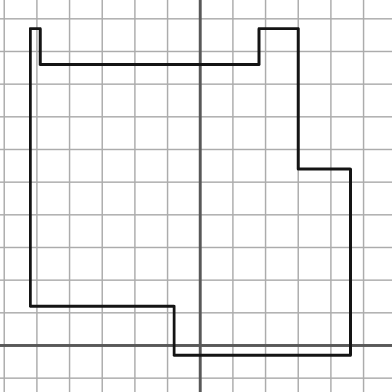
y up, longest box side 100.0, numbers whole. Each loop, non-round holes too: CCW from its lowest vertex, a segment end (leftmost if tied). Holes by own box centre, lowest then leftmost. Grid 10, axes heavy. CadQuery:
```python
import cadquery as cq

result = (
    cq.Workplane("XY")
    .moveTo(-8.0, -3.0)
    .lineTo(46.0, -3.0)
    .lineTo(46.0, 54.0)
    .lineTo(30.0, 54.0)
    .lineTo(30.0, 97.0)
    .lineTo(18.0, 97.0)
    .lineTo(18.0, 86.0)
    .lineTo(-49.0, 86.0)
    .lineTo(-49.0, 97.0)
    .lineTo(-52.0, 97.0)
    .lineTo(-52.0, 12.0)
    .lineTo(-8.0, 12.0)
    .close()
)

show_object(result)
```